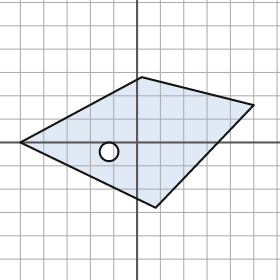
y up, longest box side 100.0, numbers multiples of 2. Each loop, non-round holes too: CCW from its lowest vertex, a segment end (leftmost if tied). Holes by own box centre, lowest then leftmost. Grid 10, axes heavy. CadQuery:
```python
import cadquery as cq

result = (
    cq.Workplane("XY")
    .moveTo(8.0, -28.0)
    .lineTo(50.0, 16.0)
    .lineTo(2.0, 28.0)
    .lineTo(-50.0, 0.0)
    .close()
    .moveTo(-12.0, -4.0)
    .circle(4.0)
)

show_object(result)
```